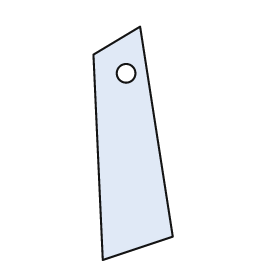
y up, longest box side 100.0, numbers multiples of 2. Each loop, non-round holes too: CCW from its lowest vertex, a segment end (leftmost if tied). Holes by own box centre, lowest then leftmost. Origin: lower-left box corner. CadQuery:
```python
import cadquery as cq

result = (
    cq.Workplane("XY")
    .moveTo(4.0, 0.0)
    .lineTo(34.0, 10.0)
    .lineTo(20.0, 100.0)
    .lineTo(0.0, 88.0)
    .close()
    .moveTo(14.0, 80.0)
    .circle(4.0)
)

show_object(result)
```